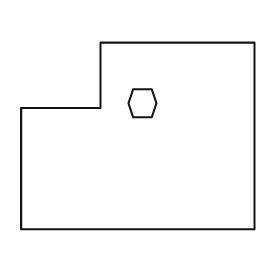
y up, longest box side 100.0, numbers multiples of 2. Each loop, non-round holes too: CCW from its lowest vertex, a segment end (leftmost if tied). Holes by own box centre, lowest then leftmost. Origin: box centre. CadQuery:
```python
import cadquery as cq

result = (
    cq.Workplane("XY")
    .moveTo(-50.0, -40.0)
    .lineTo(50.0, -40.0)
    .lineTo(50.0, 40.0)
    .lineTo(-16.0, 40.0)
    .lineTo(-16.0, 12.0)
    .lineTo(-50.0, 12.0)
    .close()
    .moveTo(-2.0, 8.0)
    .lineTo(6.0, 8.0)
    .lineTo(8.0, 14.0)
    .lineTo(6.0, 20.0)
    .lineTo(-2.0, 20.0)
    .lineTo(-4.0, 14.0)
    .close()
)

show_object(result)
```